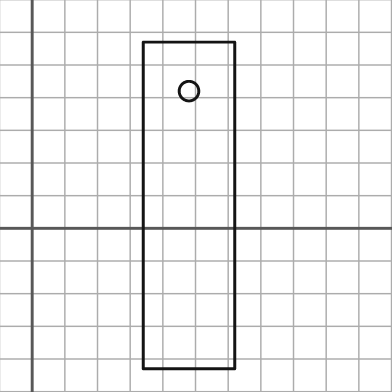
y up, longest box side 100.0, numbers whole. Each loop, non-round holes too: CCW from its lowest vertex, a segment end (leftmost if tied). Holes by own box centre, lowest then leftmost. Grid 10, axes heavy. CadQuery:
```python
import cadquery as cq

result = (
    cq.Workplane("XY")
    .moveTo(34.0, -43.0)
    .lineTo(62.0, -43.0)
    .lineTo(62.0, 57.0)
    .lineTo(34.0, 57.0)
    .close()
    .moveTo(48.0, 42.0)
    .circle(3.0)
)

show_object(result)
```